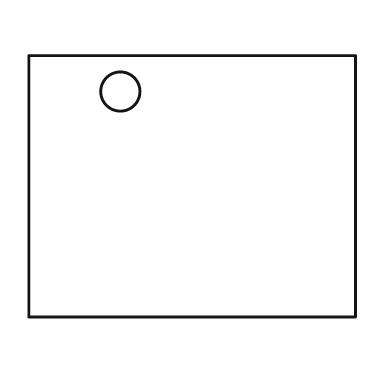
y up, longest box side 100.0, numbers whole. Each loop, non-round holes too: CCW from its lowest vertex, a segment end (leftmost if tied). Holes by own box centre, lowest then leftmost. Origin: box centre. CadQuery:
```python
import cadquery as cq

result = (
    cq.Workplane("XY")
    .moveTo(-50.0, -40.0)
    .lineTo(50.0, -40.0)
    .lineTo(50.0, 40.0)
    .lineTo(-50.0, 40.0)
    .close()
    .moveTo(-22.0, 29.0)
    .circle(6.0)
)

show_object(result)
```